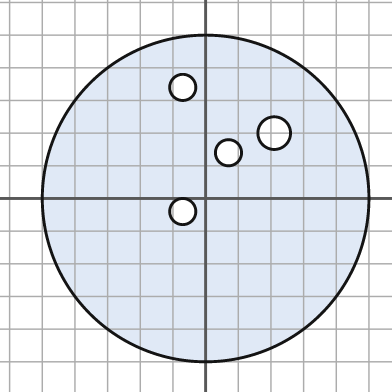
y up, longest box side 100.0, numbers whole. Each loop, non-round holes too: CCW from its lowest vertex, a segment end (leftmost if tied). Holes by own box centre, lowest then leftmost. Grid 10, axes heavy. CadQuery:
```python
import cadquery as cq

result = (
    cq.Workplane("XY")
    .moveTo(0.0, 0.0)
    .circle(50.0)
    .moveTo(-7.0, -4.0)
    .circle(4.0)
    .moveTo(7.0, 14.0)
    .circle(4.0)
    .moveTo(21.0, 20.0)
    .circle(5.0)
    .moveTo(-7.0, 34.0)
    .circle(4.0)
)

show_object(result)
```